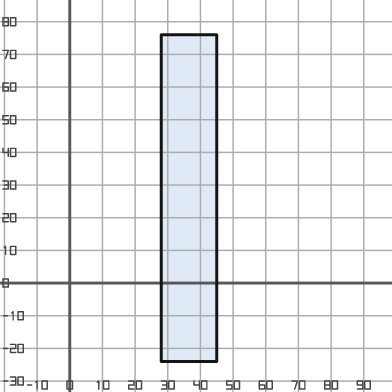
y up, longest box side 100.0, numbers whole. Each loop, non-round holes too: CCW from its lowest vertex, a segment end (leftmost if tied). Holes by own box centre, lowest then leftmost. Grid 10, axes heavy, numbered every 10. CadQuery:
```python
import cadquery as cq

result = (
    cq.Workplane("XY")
    .moveTo(28.0, -24.0)
    .lineTo(45.0, -24.0)
    .lineTo(45.0, 76.0)
    .lineTo(28.0, 76.0)
    .close()
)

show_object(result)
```